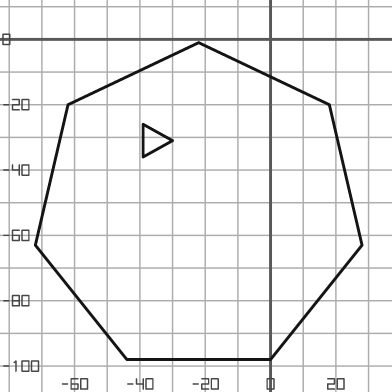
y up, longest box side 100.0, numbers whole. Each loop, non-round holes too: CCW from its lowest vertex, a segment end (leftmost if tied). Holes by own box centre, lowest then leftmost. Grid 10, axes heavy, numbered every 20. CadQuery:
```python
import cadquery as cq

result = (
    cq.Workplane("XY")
    .moveTo(-44.0, -98.0)
    .lineTo(0.0, -98.0)
    .lineTo(28.0, -63.0)
    .lineTo(18.0, -20.0)
    .lineTo(-22.0, -1.0)
    .lineTo(-62.0, -20.0)
    .lineTo(-72.0, -63.0)
    .close()
    .moveTo(-39.0, -36.0)
    .lineTo(-30.0, -31.0)
    .lineTo(-39.0, -26.0)
    .close()
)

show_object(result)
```